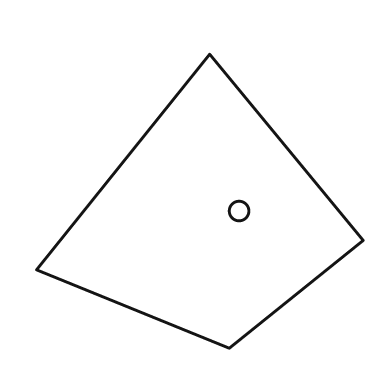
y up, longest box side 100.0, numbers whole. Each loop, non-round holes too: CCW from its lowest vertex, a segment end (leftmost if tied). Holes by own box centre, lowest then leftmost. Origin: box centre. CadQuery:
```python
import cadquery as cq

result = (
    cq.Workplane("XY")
    .moveTo(9.0, -45.0)
    .lineTo(50.0, -12.0)
    .lineTo(3.0, 45.0)
    .lineTo(-50.0, -21.0)
    .close()
    .moveTo(12.0, -3.0)
    .circle(3.0)
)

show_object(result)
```